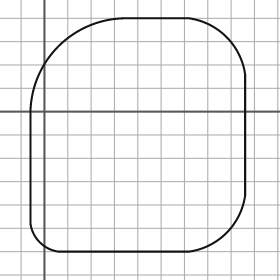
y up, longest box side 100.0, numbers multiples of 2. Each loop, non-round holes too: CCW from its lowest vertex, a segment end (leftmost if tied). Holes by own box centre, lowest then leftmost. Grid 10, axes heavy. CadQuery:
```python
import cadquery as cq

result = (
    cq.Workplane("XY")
    .moveTo(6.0, -60.0)
    .lineTo(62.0, -60.0)
    .threePointArc((78.0, -52.0), (86.0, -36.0))
    .lineTo(86.0, 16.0)
    .threePointArc((78.0, 32.0), (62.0, 40.0))
    .lineTo(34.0, 40.0)
    .threePointArc((6.0, 28.0), (-6.0, 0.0))
    .lineTo(-6.0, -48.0)
    .threePointArc((-2.0, -56.0), (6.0, -60.0))
    .close()
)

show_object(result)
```